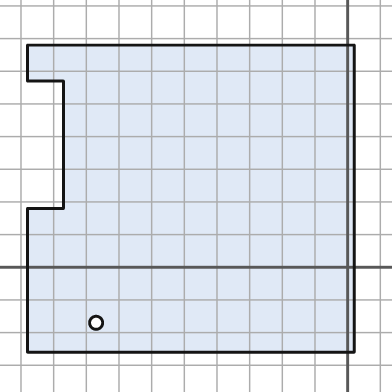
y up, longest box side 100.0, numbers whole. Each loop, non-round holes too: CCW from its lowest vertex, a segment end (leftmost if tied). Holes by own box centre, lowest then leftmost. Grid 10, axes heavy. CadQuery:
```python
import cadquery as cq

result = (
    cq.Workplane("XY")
    .moveTo(-98.0, -26.0)
    .lineTo(2.0, -26.0)
    .lineTo(2.0, 68.0)
    .lineTo(-98.0, 68.0)
    .lineTo(-98.0, 57.0)
    .lineTo(-87.0, 57.0)
    .lineTo(-87.0, 18.0)
    .lineTo(-98.0, 18.0)
    .close()
    .moveTo(-77.0, -17.0)
    .circle(2.0)
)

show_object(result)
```